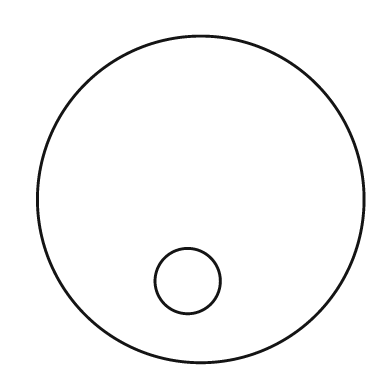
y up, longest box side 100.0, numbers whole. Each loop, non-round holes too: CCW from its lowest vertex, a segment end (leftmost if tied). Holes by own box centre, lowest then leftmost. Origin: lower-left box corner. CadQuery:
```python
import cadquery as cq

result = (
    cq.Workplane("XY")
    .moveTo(50.0, 50.0)
    .circle(50.0)
    .moveTo(46.0, 25.0)
    .circle(10.0)
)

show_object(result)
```